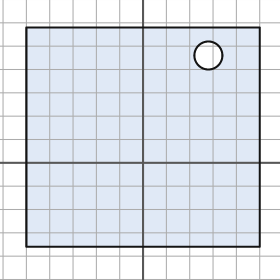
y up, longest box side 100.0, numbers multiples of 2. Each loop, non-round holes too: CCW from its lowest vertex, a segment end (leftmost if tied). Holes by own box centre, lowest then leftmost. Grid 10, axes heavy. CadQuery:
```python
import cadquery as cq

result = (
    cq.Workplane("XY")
    .moveTo(-50.0, -36.0)
    .lineTo(50.0, -36.0)
    .lineTo(50.0, 58.0)
    .lineTo(-50.0, 58.0)
    .close()
    .moveTo(28.0, 46.0)
    .circle(6.0)
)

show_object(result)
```